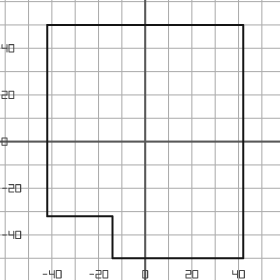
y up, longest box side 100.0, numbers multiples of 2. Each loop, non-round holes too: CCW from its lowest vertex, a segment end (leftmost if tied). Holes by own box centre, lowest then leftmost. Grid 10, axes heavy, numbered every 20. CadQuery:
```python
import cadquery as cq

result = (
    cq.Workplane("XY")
    .moveTo(-14.0, -50.0)
    .lineTo(42.0, -50.0)
    .lineTo(42.0, 50.0)
    .lineTo(-42.0, 50.0)
    .lineTo(-42.0, -32.0)
    .lineTo(-14.0, -32.0)
    .close()
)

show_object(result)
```